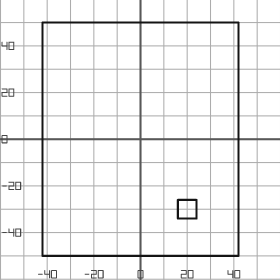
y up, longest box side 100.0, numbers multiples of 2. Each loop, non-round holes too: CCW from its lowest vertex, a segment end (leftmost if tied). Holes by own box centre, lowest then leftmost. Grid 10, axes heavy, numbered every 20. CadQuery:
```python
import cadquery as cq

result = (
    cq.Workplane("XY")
    .moveTo(-42.0, -50.0)
    .lineTo(42.0, -50.0)
    .lineTo(42.0, 50.0)
    .lineTo(-42.0, 50.0)
    .close()
    .moveTo(16.0, -34.0)
    .lineTo(24.0, -34.0)
    .lineTo(24.0, -26.0)
    .lineTo(16.0, -26.0)
    .close()
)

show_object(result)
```